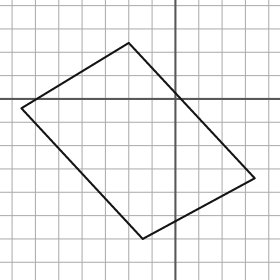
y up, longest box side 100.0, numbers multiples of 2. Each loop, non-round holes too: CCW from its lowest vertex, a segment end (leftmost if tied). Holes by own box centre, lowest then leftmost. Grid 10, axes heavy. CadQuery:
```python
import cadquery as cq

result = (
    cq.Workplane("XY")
    .moveTo(-14.0, -60.0)
    .lineTo(34.0, -34.0)
    .lineTo(-20.0, 24.0)
    .lineTo(-66.0, -4.0)
    .close()
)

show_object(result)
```